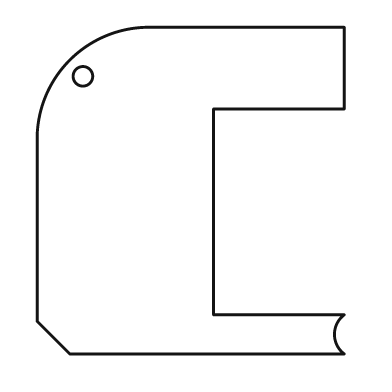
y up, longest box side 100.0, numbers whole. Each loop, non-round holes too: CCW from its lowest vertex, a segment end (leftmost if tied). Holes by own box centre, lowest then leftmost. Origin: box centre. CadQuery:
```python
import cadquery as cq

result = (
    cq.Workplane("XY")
    .moveTo(-37.0, -50.0)
    .lineTo(47.0, -50.0)
    .threePointArc((44.0, -44.0), (47.0, -38.0))
    .lineTo(7.0, -38.0)
    .lineTo(7.0, 25.0)
    .lineTo(47.0, 25.0)
    .lineTo(47.0, 50.0)
    .lineTo(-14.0, 50.0)
    .threePointArc((-37.0, 40.0), (-47.0, 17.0))
    .lineTo(-47.0, -40.0)
    .close()
    .moveTo(-33.0, 35.0)
    .circle(3.0)
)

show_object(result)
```